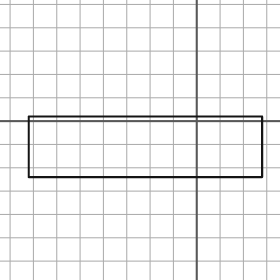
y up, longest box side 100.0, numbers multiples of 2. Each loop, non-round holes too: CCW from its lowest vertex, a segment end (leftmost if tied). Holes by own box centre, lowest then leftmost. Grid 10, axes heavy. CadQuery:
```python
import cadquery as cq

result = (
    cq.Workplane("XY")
    .moveTo(-72.0, -24.0)
    .lineTo(28.0, -24.0)
    .lineTo(28.0, 2.0)
    .lineTo(-72.0, 2.0)
    .close()
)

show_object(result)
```